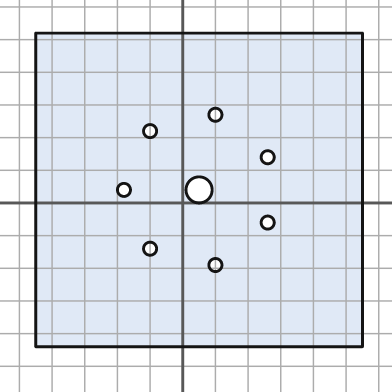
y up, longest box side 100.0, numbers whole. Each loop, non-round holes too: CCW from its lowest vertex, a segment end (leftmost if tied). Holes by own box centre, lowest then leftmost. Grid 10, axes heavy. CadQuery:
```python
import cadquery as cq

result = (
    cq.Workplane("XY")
    .moveTo(-45.0, -44.0)
    .lineTo(55.0, -44.0)
    .lineTo(55.0, 52.0)
    .lineTo(-45.0, 52.0)
    .close()
    .moveTo(10.0, -19.0)
    .circle(2.0)
    .moveTo(-10.0, -14.0)
    .circle(2.0)
    .moveTo(26.0, -6.0)
    .circle(2.0)
    .moveTo(-18.0, 4.0)
    .circle(2.0)
    .moveTo(5.0, 4.0)
    .circle(4.0)
    .moveTo(26.0, 14.0)
    .circle(2.0)
    .moveTo(-10.0, 22.0)
    .circle(2.0)
    .moveTo(10.0, 27.0)
    .circle(2.0)
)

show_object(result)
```